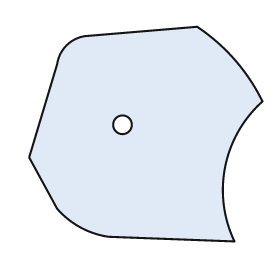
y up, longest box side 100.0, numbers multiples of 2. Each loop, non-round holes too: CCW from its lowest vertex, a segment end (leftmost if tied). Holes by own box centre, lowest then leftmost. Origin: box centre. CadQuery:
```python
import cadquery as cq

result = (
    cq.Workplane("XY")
    .moveTo(38.0, -46.0)
    .threePointArc((34.0, -14.0), (50.0, 14.0))
    .threePointArc((38.0, 32.0), (22.0, 46.0))
    .lineTo(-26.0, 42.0)
    .threePointArc((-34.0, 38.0), (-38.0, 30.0))
    .lineTo(-50.0, -10.0)
    .lineTo(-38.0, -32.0)
    .threePointArc((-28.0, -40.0), (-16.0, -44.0))
    .close()
    .moveTo(-10.0, 4.0)
    .circle(4.0)
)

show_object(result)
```